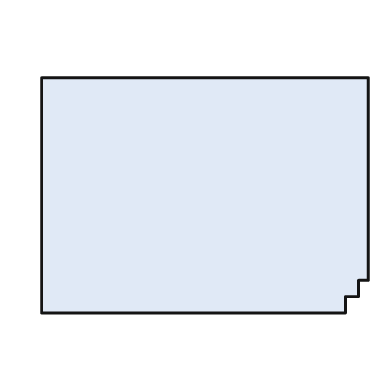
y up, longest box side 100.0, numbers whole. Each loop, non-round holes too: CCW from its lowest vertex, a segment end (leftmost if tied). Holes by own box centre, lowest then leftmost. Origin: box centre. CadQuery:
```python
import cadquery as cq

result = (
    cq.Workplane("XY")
    .moveTo(-50.0, -36.0)
    .lineTo(43.0, -36.0)
    .lineTo(43.0, -31.0)
    .lineTo(47.0, -31.0)
    .lineTo(47.0, -26.0)
    .lineTo(50.0, -26.0)
    .lineTo(50.0, 36.0)
    .lineTo(-50.0, 36.0)
    .close()
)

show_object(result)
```